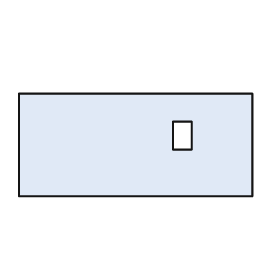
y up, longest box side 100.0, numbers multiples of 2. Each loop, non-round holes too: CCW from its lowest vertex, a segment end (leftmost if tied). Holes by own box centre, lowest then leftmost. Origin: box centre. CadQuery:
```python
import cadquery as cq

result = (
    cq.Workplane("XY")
    .moveTo(-50.0, -22.0)
    .lineTo(50.0, -22.0)
    .lineTo(50.0, 22.0)
    .lineTo(-50.0, 22.0)
    .close()
    .moveTo(16.0, -2.0)
    .lineTo(24.0, -2.0)
    .lineTo(24.0, 10.0)
    .lineTo(16.0, 10.0)
    .close()
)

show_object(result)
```